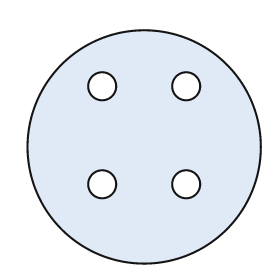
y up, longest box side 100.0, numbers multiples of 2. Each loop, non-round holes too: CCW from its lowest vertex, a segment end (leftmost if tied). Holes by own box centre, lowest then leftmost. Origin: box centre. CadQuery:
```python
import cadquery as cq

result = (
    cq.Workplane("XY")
    .moveTo(0.0, 0.0)
    .circle(50.0)
    .moveTo(-18.0, -16.0)
    .circle(6.0)
    .moveTo(18.0, -16.0)
    .circle(6.0)
    .moveTo(-18.0, 26.0)
    .circle(6.0)
    .moveTo(18.0, 26.0)
    .circle(6.0)
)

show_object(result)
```